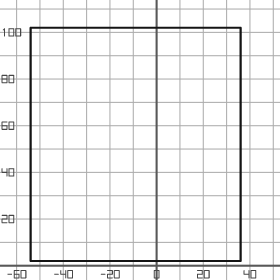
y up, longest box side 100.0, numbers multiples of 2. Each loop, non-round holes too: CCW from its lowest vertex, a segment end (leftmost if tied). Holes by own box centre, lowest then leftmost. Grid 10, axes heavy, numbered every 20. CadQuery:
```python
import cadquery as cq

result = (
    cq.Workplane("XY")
    .moveTo(-54.0, 2.0)
    .lineTo(36.0, 2.0)
    .lineTo(36.0, 102.0)
    .lineTo(-54.0, 102.0)
    .close()
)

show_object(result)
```